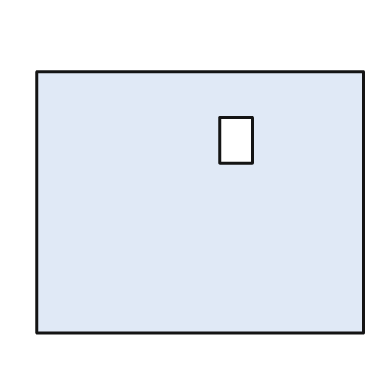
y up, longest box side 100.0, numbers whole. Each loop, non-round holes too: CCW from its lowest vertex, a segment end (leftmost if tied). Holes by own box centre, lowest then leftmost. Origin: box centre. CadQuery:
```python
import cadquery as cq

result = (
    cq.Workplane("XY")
    .moveTo(-50.0, -40.0)
    .lineTo(50.0, -40.0)
    .lineTo(50.0, 40.0)
    .lineTo(-50.0, 40.0)
    .close()
    .moveTo(6.0, 12.0)
    .lineTo(16.0, 12.0)
    .lineTo(16.0, 26.0)
    .lineTo(6.0, 26.0)
    .close()
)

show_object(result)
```